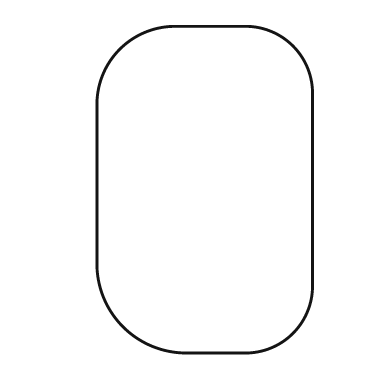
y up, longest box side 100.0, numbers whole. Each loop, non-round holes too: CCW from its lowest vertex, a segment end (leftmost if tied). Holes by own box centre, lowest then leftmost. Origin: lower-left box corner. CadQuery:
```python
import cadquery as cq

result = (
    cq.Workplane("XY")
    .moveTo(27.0, 0.0)
    .lineTo(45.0, 0.0)
    .threePointArc((60.0, 6.0), (66.0, 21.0))
    .lineTo(66.0, 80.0)
    .threePointArc((60.0, 94.0), (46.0, 100.0))
    .lineTo(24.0, 100.0)
    .threePointArc((7.0, 93.0), (0.0, 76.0))
    .lineTo(0.0, 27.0)
    .threePointArc((8.0, 8.0), (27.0, 0.0))
    .close()
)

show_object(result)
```